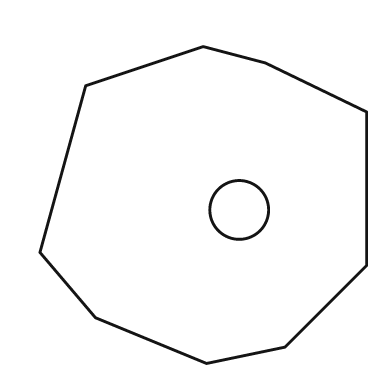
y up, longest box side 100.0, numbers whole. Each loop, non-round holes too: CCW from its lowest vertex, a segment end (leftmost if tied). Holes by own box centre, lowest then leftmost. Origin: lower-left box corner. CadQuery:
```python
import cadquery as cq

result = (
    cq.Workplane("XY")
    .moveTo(51.0, 0.0)
    .lineTo(75.0, 5.0)
    .lineTo(100.0, 30.0)
    .lineTo(100.0, 77.0)
    .lineTo(69.0, 92.0)
    .lineTo(50.0, 97.0)
    .lineTo(14.0, 85.0)
    .lineTo(0.0, 34.0)
    .lineTo(17.0, 14.0)
    .close()
    .moveTo(61.0, 47.0)
    .circle(9.0)
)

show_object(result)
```